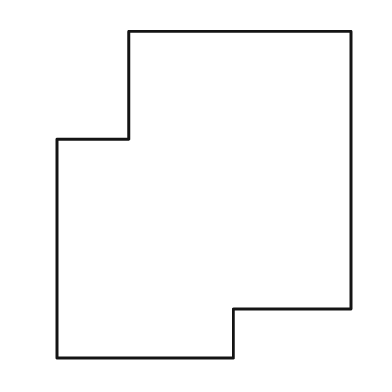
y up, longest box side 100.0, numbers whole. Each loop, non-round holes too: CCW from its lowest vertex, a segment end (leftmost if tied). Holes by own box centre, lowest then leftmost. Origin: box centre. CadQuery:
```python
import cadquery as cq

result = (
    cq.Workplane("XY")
    .moveTo(-45.0, -50.0)
    .lineTo(9.0, -50.0)
    .lineTo(9.0, -35.0)
    .lineTo(45.0, -35.0)
    .lineTo(45.0, 50.0)
    .lineTo(-23.0, 50.0)
    .lineTo(-23.0, 17.0)
    .lineTo(-45.0, 17.0)
    .close()
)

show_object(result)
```